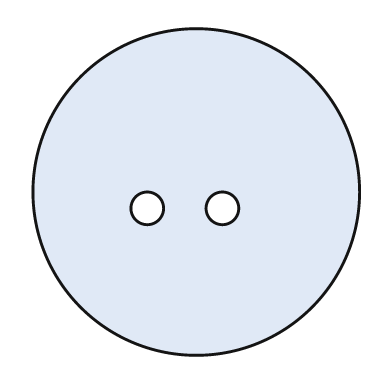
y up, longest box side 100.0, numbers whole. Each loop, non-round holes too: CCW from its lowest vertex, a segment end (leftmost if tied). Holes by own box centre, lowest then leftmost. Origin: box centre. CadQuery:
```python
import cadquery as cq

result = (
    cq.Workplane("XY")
    .moveTo(0.0, 0.0)
    .circle(50.0)
    .moveTo(-15.0, -5.0)
    .circle(5.0)
    .moveTo(8.0, -5.0)
    .circle(5.0)
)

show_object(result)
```